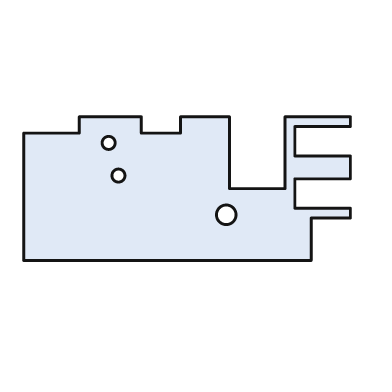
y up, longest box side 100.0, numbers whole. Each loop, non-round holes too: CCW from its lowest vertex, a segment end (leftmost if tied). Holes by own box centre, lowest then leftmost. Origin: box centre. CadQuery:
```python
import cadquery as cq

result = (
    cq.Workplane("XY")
    .moveTo(-50.0, -22.0)
    .lineTo(38.0, -22.0)
    .lineTo(38.0, -9.0)
    .lineTo(50.0, -9.0)
    .lineTo(50.0, -6.0)
    .lineTo(33.0, -6.0)
    .lineTo(33.0, 3.0)
    .lineTo(50.0, 3.0)
    .lineTo(50.0, 10.0)
    .lineTo(33.0, 10.0)
    .lineTo(33.0, 19.0)
    .lineTo(50.0, 19.0)
    .lineTo(50.0, 22.0)
    .lineTo(30.0, 22.0)
    .lineTo(30.0, 0.0)
    .lineTo(13.0, 0.0)
    .lineTo(13.0, 22.0)
    .lineTo(-2.0, 22.0)
    .lineTo(-2.0, 17.0)
    .lineTo(-14.0, 17.0)
    .lineTo(-14.0, 22.0)
    .lineTo(-33.0, 22.0)
    .lineTo(-33.0, 17.0)
    .lineTo(-50.0, 17.0)
    .close()
    .moveTo(12.0, -8.0)
    .circle(3.0)
    .moveTo(-21.0, 4.0)
    .circle(2.0)
    .moveTo(-24.0, 14.0)
    .circle(2.0)
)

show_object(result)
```